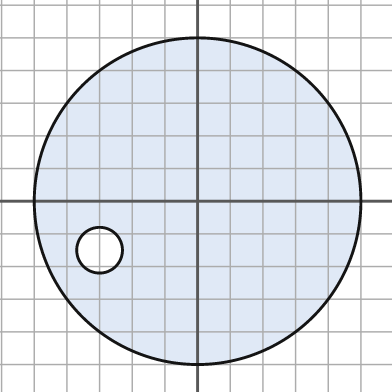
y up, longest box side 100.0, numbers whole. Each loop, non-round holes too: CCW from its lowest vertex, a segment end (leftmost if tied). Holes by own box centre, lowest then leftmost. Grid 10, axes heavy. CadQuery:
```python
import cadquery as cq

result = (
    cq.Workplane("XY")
    .moveTo(0.0, 0.0)
    .circle(50.0)
    .moveTo(-30.0, -15.0)
    .circle(7.0)
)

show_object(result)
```